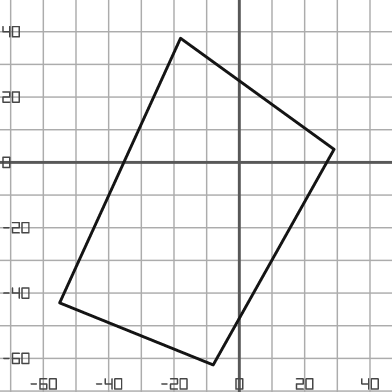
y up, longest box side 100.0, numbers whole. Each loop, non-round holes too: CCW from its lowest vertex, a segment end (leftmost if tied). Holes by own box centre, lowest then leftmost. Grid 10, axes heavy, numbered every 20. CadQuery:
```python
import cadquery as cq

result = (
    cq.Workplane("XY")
    .moveTo(-8.0, -62.0)
    .lineTo(29.0, 4.0)
    .lineTo(-18.0, 38.0)
    .lineTo(-55.0, -43.0)
    .close()
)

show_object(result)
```